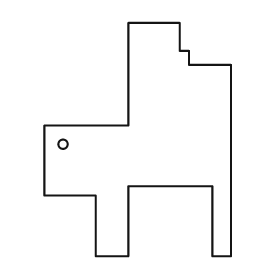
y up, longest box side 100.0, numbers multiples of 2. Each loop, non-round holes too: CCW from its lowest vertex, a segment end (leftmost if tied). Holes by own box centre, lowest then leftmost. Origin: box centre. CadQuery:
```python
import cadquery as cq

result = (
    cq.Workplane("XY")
    .moveTo(-18.0, -50.0)
    .lineTo(-4.0, -50.0)
    .lineTo(-4.0, -20.0)
    .lineTo(32.0, -20.0)
    .lineTo(32.0, -50.0)
    .lineTo(40.0, -50.0)
    .lineTo(40.0, 32.0)
    .lineTo(22.0, 32.0)
    .lineTo(22.0, 38.0)
    .lineTo(18.0, 38.0)
    .lineTo(18.0, 50.0)
    .lineTo(-4.0, 50.0)
    .lineTo(-4.0, 6.0)
    .lineTo(-40.0, 6.0)
    .lineTo(-40.0, -24.0)
    .lineTo(-18.0, -24.0)
    .close()
    .moveTo(-32.0, -2.0)
    .circle(2.0)
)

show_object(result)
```